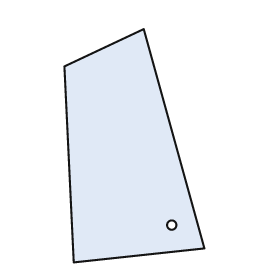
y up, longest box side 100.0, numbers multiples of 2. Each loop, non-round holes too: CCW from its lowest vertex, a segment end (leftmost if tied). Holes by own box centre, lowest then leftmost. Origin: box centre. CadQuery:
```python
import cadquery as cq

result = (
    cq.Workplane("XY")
    .moveTo(-26.0, -50.0)
    .lineTo(30.0, -44.0)
    .lineTo(4.0, 50.0)
    .lineTo(-30.0, 34.0)
    .close()
    .moveTo(16.0, -34.0)
    .circle(2.0)
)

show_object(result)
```